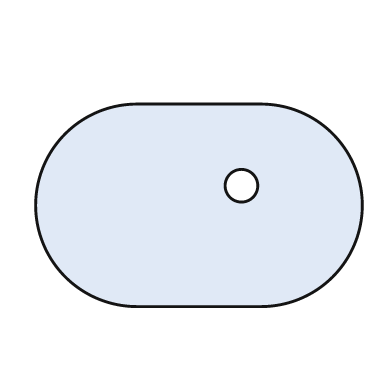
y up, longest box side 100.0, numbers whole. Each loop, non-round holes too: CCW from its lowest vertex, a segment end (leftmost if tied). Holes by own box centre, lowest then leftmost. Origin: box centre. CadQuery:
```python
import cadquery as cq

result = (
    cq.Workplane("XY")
    .moveTo(-19.0, -31.0)
    .lineTo(19.0, -31.0)
    .threePointArc((50.0, 0.0), (19.0, 31.0))
    .lineTo(-19.0, 31.0)
    .threePointArc((-50.0, 0.0), (-19.0, -31.0))
    .close()
    .moveTo(13.0, 6.0)
    .circle(5.0)
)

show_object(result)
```